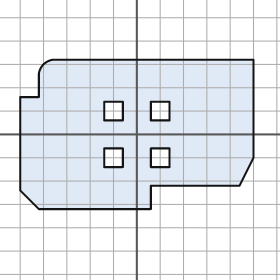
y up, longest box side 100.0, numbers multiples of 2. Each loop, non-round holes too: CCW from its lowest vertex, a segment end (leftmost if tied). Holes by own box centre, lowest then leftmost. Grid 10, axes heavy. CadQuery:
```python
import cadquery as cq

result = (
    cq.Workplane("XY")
    .moveTo(-42.0, -32.0)
    .lineTo(6.0, -32.0)
    .lineTo(6.0, -22.0)
    .lineTo(44.0, -22.0)
    .lineTo(50.0, -10.0)
    .lineTo(50.0, 32.0)
    .lineTo(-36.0, 32.0)
    .threePointArc((-40.0, 30.0), (-42.0, 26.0))
    .lineTo(-42.0, 16.0)
    .lineTo(-50.0, 16.0)
    .lineTo(-50.0, -24.0)
    .close()
    .moveTo(-14.0, -14.0)
    .lineTo(-6.0, -14.0)
    .lineTo(-6.0, -6.0)
    .lineTo(-14.0, -6.0)
    .close()
    .moveTo(6.0, -14.0)
    .lineTo(14.0, -14.0)
    .lineTo(14.0, -6.0)
    .lineTo(6.0, -6.0)
    .close()
    .moveTo(-14.0, 6.0)
    .lineTo(-6.0, 6.0)
    .lineTo(-6.0, 14.0)
    .lineTo(-14.0, 14.0)
    .close()
    .moveTo(6.0, 6.0)
    .lineTo(14.0, 6.0)
    .lineTo(14.0, 14.0)
    .lineTo(6.0, 14.0)
    .close()
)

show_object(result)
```